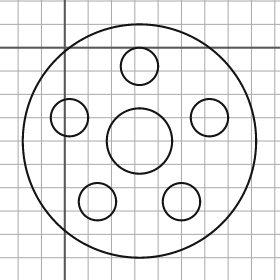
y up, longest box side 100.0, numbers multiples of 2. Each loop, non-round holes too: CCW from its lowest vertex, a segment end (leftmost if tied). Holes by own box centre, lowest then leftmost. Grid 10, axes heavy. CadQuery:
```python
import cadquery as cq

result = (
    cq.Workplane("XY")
    .moveTo(32.0, -40.0)
    .circle(50.0)
    .moveTo(14.0, -66.0)
    .circle(8.0)
    .moveTo(50.0, -66.0)
    .circle(8.0)
    .moveTo(32.0, -40.0)
    .circle(14.0)
    .moveTo(2.0, -30.0)
    .circle(8.0)
    .moveTo(62.0, -30.0)
    .circle(8.0)
    .moveTo(32.0, -8.0)
    .circle(8.0)
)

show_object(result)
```